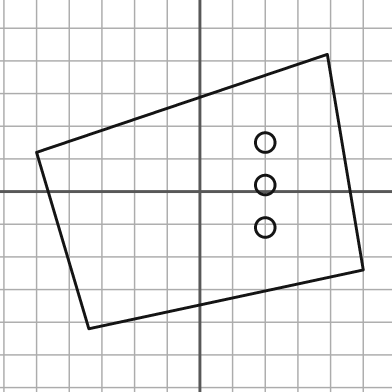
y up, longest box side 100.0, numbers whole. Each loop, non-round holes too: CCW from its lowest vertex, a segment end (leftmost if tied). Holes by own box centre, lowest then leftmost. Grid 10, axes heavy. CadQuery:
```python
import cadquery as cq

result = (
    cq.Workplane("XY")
    .moveTo(-34.0, -42.0)
    .lineTo(50.0, -24.0)
    .lineTo(39.0, 42.0)
    .lineTo(-50.0, 12.0)
    .close()
    .moveTo(20.0, -11.0)
    .circle(3.0)
    .moveTo(20.0, 2.0)
    .circle(3.0)
    .moveTo(20.0, 15.0)
    .circle(3.0)
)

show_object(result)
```